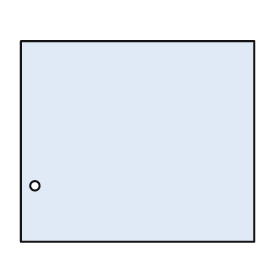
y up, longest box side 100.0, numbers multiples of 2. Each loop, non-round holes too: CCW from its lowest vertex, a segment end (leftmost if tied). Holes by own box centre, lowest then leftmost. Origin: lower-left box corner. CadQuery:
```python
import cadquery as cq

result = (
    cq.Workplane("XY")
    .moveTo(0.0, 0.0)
    .lineTo(100.0, 0.0)
    .lineTo(100.0, 86.0)
    .lineTo(0.0, 86.0)
    .close()
    .moveTo(6.0, 24.0)
    .circle(2.0)
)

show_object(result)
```